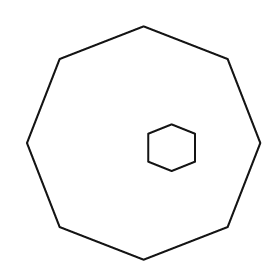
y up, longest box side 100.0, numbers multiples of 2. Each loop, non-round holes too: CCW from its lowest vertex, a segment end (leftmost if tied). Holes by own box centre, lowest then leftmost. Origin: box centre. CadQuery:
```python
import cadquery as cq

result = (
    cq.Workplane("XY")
    .moveTo(0.0, -50.0)
    .lineTo(36.0, -36.0)
    .lineTo(50.0, 0.0)
    .lineTo(36.0, 36.0)
    .lineTo(0.0, 50.0)
    .lineTo(-36.0, 36.0)
    .lineTo(-50.0, 0.0)
    .lineTo(-36.0, -36.0)
    .close()
    .moveTo(12.0, -12.0)
    .lineTo(22.0, -8.0)
    .lineTo(22.0, 4.0)
    .lineTo(12.0, 8.0)
    .lineTo(2.0, 4.0)
    .lineTo(2.0, -8.0)
    .close()
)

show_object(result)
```